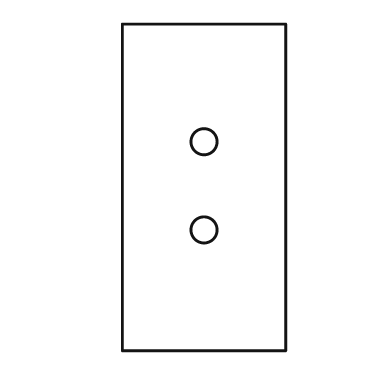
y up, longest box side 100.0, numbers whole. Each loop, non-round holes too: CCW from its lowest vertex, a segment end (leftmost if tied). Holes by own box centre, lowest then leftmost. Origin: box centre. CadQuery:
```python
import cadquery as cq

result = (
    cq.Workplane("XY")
    .moveTo(-25.0, -50.0)
    .lineTo(25.0, -50.0)
    .lineTo(25.0, 50.0)
    .lineTo(-25.0, 50.0)
    .close()
    .moveTo(0.0, -13.0)
    .circle(4.0)
    .moveTo(0.0, 14.0)
    .circle(4.0)
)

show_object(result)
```